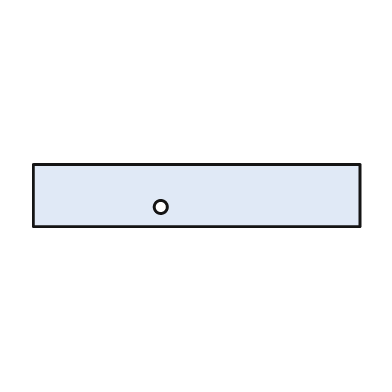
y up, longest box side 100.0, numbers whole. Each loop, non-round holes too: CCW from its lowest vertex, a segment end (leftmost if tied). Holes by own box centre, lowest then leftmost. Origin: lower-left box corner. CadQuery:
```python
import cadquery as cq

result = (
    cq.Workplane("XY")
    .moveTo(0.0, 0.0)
    .lineTo(100.0, 0.0)
    .lineTo(100.0, 19.0)
    .lineTo(0.0, 19.0)
    .close()
    .moveTo(39.0, 6.0)
    .circle(2.0)
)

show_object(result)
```